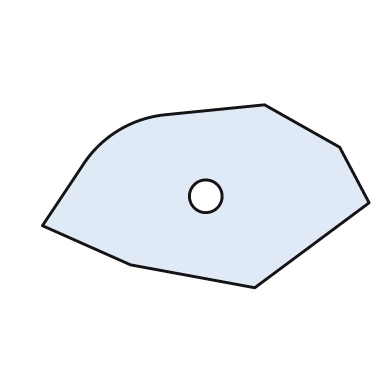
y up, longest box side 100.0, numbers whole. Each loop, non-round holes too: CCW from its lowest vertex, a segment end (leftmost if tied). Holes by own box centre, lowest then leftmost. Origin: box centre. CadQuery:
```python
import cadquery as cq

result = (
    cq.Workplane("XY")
    .moveTo(15.0, -28.0)
    .lineTo(50.0, -2.0)
    .lineTo(41.0, 15.0)
    .lineTo(18.0, 28.0)
    .lineTo(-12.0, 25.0)
    .threePointArc((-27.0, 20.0), (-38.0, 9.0))
    .lineTo(-50.0, -9.0)
    .lineTo(-23.0, -21.0)
    .close()
    .moveTo(0.0, 0.0)
    .circle(5.0)
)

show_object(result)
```